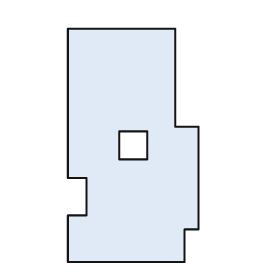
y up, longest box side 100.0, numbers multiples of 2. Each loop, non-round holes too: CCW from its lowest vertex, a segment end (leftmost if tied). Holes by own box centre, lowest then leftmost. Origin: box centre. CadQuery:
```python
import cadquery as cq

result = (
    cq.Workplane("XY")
    .moveTo(-28.0, -50.0)
    .lineTo(22.0, -50.0)
    .lineTo(22.0, -36.0)
    .lineTo(28.0, -36.0)
    .lineTo(28.0, 8.0)
    .lineTo(18.0, 8.0)
    .lineTo(18.0, 50.0)
    .lineTo(-28.0, 50.0)
    .lineTo(-28.0, -14.0)
    .lineTo(-20.0, -14.0)
    .lineTo(-20.0, -30.0)
    .lineTo(-28.0, -30.0)
    .close()
    .moveTo(-6.0, -6.0)
    .lineTo(6.0, -6.0)
    .lineTo(6.0, 6.0)
    .lineTo(-6.0, 6.0)
    .close()
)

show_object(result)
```